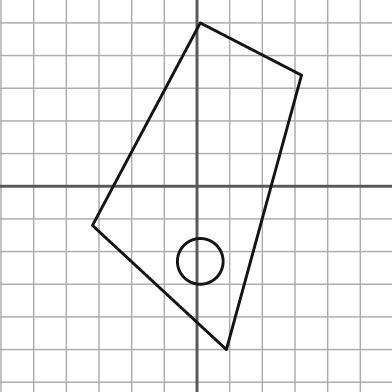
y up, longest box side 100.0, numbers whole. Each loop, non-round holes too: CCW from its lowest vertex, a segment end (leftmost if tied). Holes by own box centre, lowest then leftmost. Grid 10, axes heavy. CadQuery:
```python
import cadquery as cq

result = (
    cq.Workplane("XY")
    .moveTo(9.0, -50.0)
    .lineTo(32.0, 34.0)
    .lineTo(1.0, 50.0)
    .lineTo(-32.0, -12.0)
    .close()
    .moveTo(1.0, -23.0)
    .circle(7.0)
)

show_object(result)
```